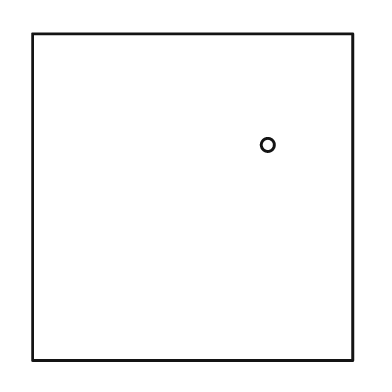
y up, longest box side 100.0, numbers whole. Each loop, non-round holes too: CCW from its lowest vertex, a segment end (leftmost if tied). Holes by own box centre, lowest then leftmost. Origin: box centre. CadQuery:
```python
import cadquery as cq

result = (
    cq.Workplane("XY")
    .moveTo(-49.0, -50.0)
    .lineTo(49.0, -50.0)
    .lineTo(49.0, 50.0)
    .lineTo(-49.0, 50.0)
    .close()
    .moveTo(23.0, 16.0)
    .circle(2.0)
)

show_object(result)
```